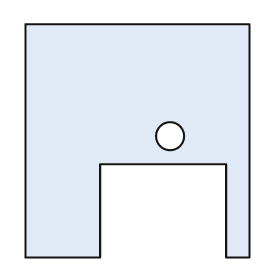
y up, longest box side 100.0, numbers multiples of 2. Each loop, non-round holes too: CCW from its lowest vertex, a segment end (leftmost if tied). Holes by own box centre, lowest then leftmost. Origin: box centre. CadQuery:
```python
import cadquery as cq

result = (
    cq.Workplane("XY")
    .moveTo(-48.0, -50.0)
    .lineTo(-16.0, -50.0)
    .lineTo(-16.0, -10.0)
    .lineTo(38.0, -10.0)
    .lineTo(38.0, -50.0)
    .lineTo(48.0, -50.0)
    .lineTo(48.0, 50.0)
    .lineTo(-48.0, 50.0)
    .close()
    .moveTo(14.0, 2.0)
    .circle(6.0)
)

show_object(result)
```